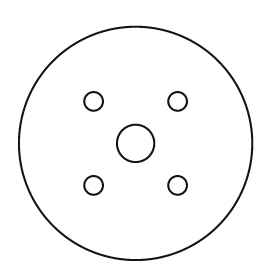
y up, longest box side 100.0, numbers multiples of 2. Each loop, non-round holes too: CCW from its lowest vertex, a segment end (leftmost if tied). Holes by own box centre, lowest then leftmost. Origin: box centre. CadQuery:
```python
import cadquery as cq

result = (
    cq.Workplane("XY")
    .moveTo(0.0, 0.0)
    .circle(50.0)
    .moveTo(-18.0, -18.0)
    .circle(4.0)
    .moveTo(18.0, -18.0)
    .circle(4.0)
    .moveTo(0.0, 0.0)
    .circle(8.0)
    .moveTo(-18.0, 18.0)
    .circle(4.0)
    .moveTo(18.0, 18.0)
    .circle(4.0)
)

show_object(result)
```